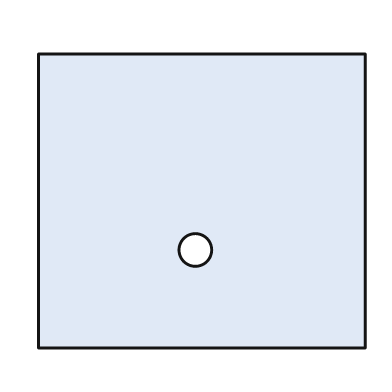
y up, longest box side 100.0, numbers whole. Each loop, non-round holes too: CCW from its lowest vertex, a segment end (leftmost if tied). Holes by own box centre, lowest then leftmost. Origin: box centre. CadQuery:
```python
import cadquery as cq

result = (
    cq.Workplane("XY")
    .moveTo(-50.0, -45.0)
    .lineTo(50.0, -45.0)
    .lineTo(50.0, 45.0)
    .lineTo(-50.0, 45.0)
    .close()
    .moveTo(-2.0, -15.0)
    .circle(5.0)
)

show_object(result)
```